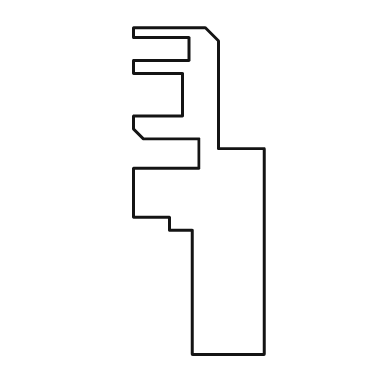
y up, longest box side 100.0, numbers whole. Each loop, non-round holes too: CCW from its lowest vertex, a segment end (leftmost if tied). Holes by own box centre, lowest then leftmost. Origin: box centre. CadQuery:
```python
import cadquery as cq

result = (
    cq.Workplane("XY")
    .moveTo(-2.0, -50.0)
    .lineTo(20.0, -50.0)
    .lineTo(20.0, 13.0)
    .lineTo(6.0, 13.0)
    .lineTo(6.0, 46.0)
    .lineTo(2.0, 50.0)
    .lineTo(-20.0, 50.0)
    .lineTo(-20.0, 47.0)
    .lineTo(-3.0, 47.0)
    .lineTo(-3.0, 40.0)
    .lineTo(-20.0, 40.0)
    .lineTo(-20.0, 36.0)
    .lineTo(-5.0, 36.0)
    .lineTo(-5.0, 23.0)
    .lineTo(-20.0, 23.0)
    .lineTo(-20.0, 19.0)
    .lineTo(-17.0, 16.0)
    .lineTo(0.0, 16.0)
    .lineTo(0.0, 7.0)
    .lineTo(-20.0, 7.0)
    .lineTo(-20.0, -8.0)
    .lineTo(-9.0, -8.0)
    .lineTo(-9.0, -12.0)
    .lineTo(-2.0, -12.0)
    .close()
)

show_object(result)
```